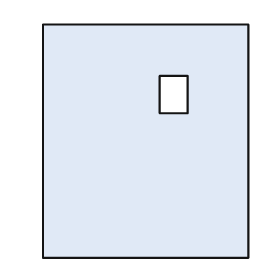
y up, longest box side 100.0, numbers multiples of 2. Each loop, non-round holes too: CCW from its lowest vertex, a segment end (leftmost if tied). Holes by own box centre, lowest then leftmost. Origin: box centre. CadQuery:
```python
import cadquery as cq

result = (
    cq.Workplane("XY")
    .moveTo(-44.0, -50.0)
    .lineTo(44.0, -50.0)
    .lineTo(44.0, 50.0)
    .lineTo(-44.0, 50.0)
    .close()
    .moveTo(6.0, 12.0)
    .lineTo(18.0, 12.0)
    .lineTo(18.0, 28.0)
    .lineTo(6.0, 28.0)
    .close()
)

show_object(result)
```